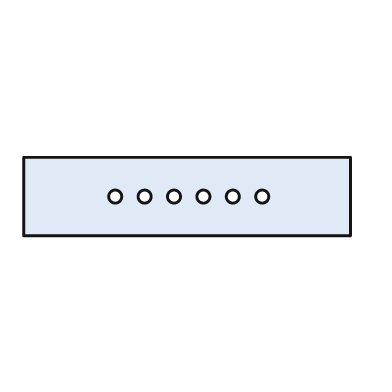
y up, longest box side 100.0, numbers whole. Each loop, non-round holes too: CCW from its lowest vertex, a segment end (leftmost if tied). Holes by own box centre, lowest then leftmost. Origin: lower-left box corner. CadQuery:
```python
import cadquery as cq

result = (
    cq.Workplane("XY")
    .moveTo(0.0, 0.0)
    .lineTo(100.0, 0.0)
    .lineTo(100.0, 24.0)
    .lineTo(0.0, 24.0)
    .close()
    .moveTo(28.0, 12.0)
    .circle(2.0)
    .moveTo(37.0, 12.0)
    .circle(2.0)
    .moveTo(46.0, 12.0)
    .circle(2.0)
    .moveTo(55.0, 12.0)
    .circle(2.0)
    .moveTo(64.0, 12.0)
    .circle(2.0)
    .moveTo(73.0, 12.0)
    .circle(2.0)
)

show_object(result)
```